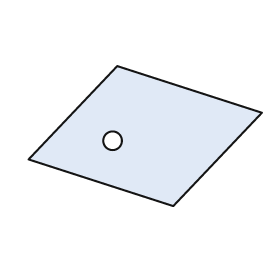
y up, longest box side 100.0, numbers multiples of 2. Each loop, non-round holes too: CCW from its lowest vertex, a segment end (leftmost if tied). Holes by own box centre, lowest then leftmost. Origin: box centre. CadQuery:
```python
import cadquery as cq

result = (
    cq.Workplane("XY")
    .moveTo(12.0, -30.0)
    .lineTo(50.0, 10.0)
    .lineTo(-12.0, 30.0)
    .lineTo(-50.0, -10.0)
    .close()
    .moveTo(-14.0, -2.0)
    .circle(4.0)
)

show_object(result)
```